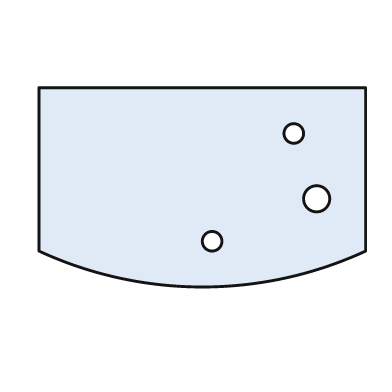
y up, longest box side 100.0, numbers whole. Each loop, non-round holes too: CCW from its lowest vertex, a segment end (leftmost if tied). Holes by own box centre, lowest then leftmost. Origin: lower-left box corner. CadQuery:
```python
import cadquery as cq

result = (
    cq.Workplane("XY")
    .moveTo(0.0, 11.0)
    .threePointArc((50.0, 0.0), (100.0, 11.0))
    .lineTo(100.0, 61.0)
    .lineTo(0.0, 61.0)
    .close()
    .moveTo(53.0, 14.0)
    .circle(3.0)
    .moveTo(85.0, 27.0)
    .circle(4.0)
    .moveTo(78.0, 47.0)
    .circle(3.0)
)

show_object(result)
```